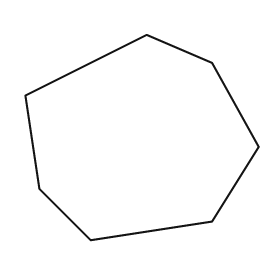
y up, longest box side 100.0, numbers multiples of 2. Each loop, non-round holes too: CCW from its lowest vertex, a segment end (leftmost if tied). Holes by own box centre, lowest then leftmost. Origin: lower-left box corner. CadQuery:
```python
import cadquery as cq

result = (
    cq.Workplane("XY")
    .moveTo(28.0, 0.0)
    .lineTo(80.0, 8.0)
    .lineTo(100.0, 40.0)
    .lineTo(80.0, 76.0)
    .lineTo(52.0, 88.0)
    .lineTo(0.0, 62.0)
    .lineTo(6.0, 22.0)
    .close()
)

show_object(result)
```